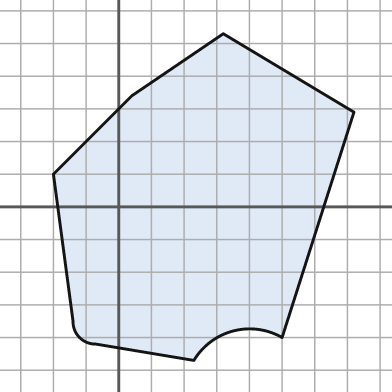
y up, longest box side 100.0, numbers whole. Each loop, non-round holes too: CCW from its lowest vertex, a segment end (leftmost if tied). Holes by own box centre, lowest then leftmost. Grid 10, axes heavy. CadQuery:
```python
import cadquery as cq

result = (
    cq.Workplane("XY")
    .moveTo(23.0, -47.0)
    .threePointArc((35.0, -38.0), (50.0, -40.0))
    .lineTo(72.0, 29.0)
    .lineTo(32.0, 53.0)
    .lineTo(4.0, 34.0)
    .lineTo(-20.0, 10.0)
    .lineTo(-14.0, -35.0)
    .threePointArc((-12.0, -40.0), (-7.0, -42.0))
    .close()
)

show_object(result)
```